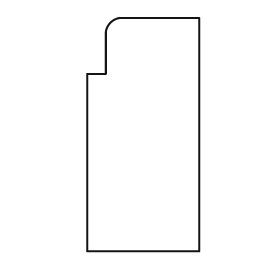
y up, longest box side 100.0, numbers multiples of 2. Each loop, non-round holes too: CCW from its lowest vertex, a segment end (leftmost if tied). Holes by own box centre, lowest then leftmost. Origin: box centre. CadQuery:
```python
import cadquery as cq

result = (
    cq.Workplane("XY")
    .moveTo(-24.0, -50.0)
    .lineTo(24.0, -50.0)
    .lineTo(24.0, 50.0)
    .lineTo(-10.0, 50.0)
    .threePointArc((-14.0, 48.0), (-16.0, 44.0))
    .lineTo(-16.0, 26.0)
    .lineTo(-24.0, 26.0)
    .close()
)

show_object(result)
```